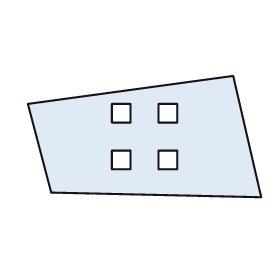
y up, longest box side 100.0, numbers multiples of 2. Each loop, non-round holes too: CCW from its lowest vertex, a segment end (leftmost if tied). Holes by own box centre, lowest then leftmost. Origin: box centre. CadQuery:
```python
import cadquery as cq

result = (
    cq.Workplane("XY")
    .moveTo(50.0, -26.0)
    .lineTo(38.0, 26.0)
    .lineTo(-50.0, 14.0)
    .lineTo(-40.0, -24.0)
    .close()
    .moveTo(-14.0, -14.0)
    .lineTo(-6.0, -14.0)
    .lineTo(-6.0, -6.0)
    .lineTo(-14.0, -6.0)
    .close()
    .moveTo(6.0, -14.0)
    .lineTo(14.0, -14.0)
    .lineTo(14.0, -6.0)
    .lineTo(6.0, -6.0)
    .close()
    .moveTo(-14.0, 6.0)
    .lineTo(-6.0, 6.0)
    .lineTo(-6.0, 14.0)
    .lineTo(-14.0, 14.0)
    .close()
    .moveTo(6.0, 6.0)
    .lineTo(14.0, 6.0)
    .lineTo(14.0, 14.0)
    .lineTo(6.0, 14.0)
    .close()
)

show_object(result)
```